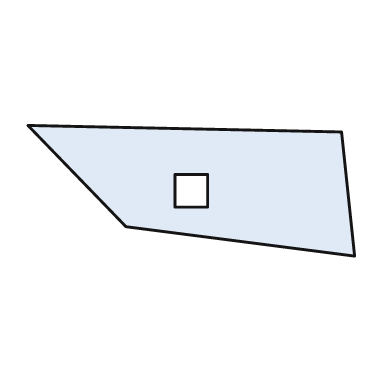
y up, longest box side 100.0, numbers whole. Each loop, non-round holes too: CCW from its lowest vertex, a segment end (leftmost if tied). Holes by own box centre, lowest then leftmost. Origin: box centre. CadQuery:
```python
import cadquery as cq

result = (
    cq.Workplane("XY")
    .moveTo(50.0, -20.0)
    .lineTo(46.0, 18.0)
    .lineTo(-50.0, 20.0)
    .lineTo(-20.0, -11.0)
    .close()
    .moveTo(-5.0, -5.0)
    .lineTo(5.0, -5.0)
    .lineTo(5.0, 5.0)
    .lineTo(-5.0, 5.0)
    .close()
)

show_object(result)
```